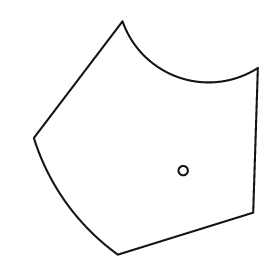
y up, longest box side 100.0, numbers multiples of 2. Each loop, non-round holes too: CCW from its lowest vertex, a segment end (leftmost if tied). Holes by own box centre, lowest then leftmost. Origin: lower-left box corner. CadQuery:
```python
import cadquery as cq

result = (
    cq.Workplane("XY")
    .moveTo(36.0, 0.0)
    .lineTo(94.0, 18.0)
    .lineTo(96.0, 80.0)
    .threePointArc((62.0, 76.0), (38.0, 100.0))
    .lineTo(0.0, 50.0)
    .threePointArc((14.0, 22.0), (36.0, 0.0))
    .close()
    .moveTo(64.0, 36.0)
    .circle(2.0)
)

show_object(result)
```